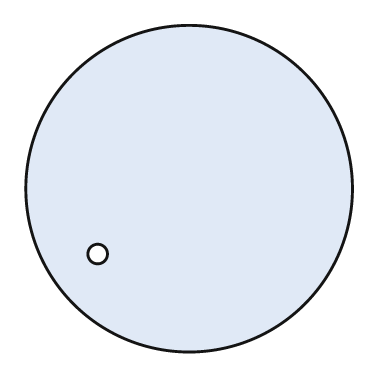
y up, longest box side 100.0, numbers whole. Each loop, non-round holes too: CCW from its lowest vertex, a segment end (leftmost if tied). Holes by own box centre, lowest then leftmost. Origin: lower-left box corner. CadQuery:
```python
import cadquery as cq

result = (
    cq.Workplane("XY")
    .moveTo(50.0, 50.0)
    .circle(50.0)
    .moveTo(22.0, 30.0)
    .circle(3.0)
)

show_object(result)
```